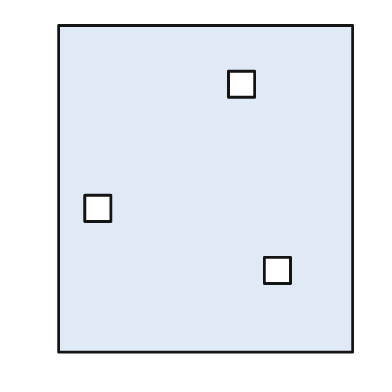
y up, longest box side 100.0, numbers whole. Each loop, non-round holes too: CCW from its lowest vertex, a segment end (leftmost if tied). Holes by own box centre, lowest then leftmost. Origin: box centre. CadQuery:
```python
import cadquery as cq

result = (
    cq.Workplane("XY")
    .moveTo(-45.0, -50.0)
    .lineTo(45.0, -50.0)
    .lineTo(45.0, 50.0)
    .lineTo(-45.0, 50.0)
    .close()
    .moveTo(18.0, -29.0)
    .lineTo(26.0, -29.0)
    .lineTo(26.0, -21.0)
    .lineTo(18.0, -21.0)
    .close()
    .moveTo(-37.0, -10.0)
    .lineTo(-29.0, -10.0)
    .lineTo(-29.0, -2.0)
    .lineTo(-37.0, -2.0)
    .close()
    .moveTo(7.0, 28.0)
    .lineTo(15.0, 28.0)
    .lineTo(15.0, 36.0)
    .lineTo(7.0, 36.0)
    .close()
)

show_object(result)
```